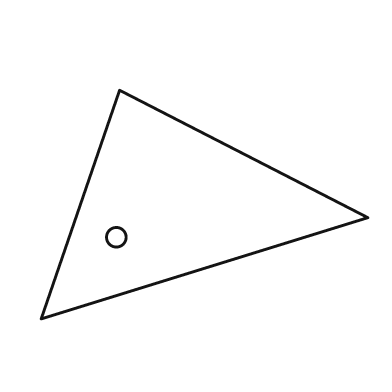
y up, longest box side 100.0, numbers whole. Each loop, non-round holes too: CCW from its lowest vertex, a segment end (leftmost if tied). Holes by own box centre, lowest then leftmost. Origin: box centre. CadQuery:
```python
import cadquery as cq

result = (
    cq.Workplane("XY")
    .moveTo(-50.0, -35.0)
    .lineTo(50.0, -4.0)
    .lineTo(-26.0, 35.0)
    .close()
    .moveTo(-27.0, -10.0)
    .circle(3.0)
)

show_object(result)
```